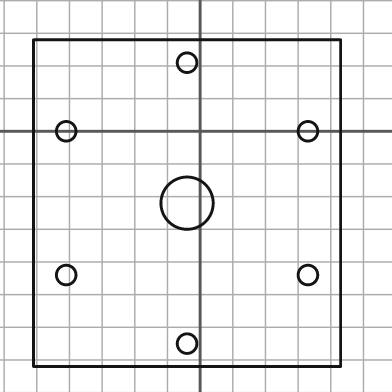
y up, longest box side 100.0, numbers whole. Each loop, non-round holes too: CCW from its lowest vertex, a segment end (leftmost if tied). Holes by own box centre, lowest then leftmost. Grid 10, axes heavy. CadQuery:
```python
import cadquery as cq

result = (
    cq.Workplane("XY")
    .moveTo(-51.0, -72.0)
    .lineTo(43.0, -72.0)
    .lineTo(43.0, 28.0)
    .lineTo(-51.0, 28.0)
    .close()
    .moveTo(-4.0, -65.0)
    .circle(3.0)
    .moveTo(-41.0, -44.0)
    .circle(3.0)
    .moveTo(33.0, -44.0)
    .circle(3.0)
    .moveTo(-4.0, -22.0)
    .circle(8.0)
    .moveTo(-41.0, 0.0)
    .circle(3.0)
    .moveTo(33.0, 0.0)
    .circle(3.0)
    .moveTo(-4.0, 21.0)
    .circle(3.0)
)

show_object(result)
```